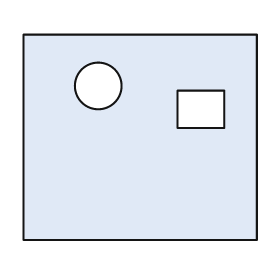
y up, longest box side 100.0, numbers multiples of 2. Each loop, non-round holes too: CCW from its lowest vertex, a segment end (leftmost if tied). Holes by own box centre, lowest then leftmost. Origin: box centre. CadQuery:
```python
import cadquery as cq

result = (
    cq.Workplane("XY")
    .moveTo(-50.0, -44.0)
    .lineTo(50.0, -44.0)
    .lineTo(50.0, 44.0)
    .lineTo(-50.0, 44.0)
    .close()
    .moveTo(16.0, 4.0)
    .lineTo(36.0, 4.0)
    .lineTo(36.0, 20.0)
    .lineTo(16.0, 20.0)
    .close()
    .moveTo(-18.0, 22.0)
    .circle(10.0)
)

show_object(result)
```